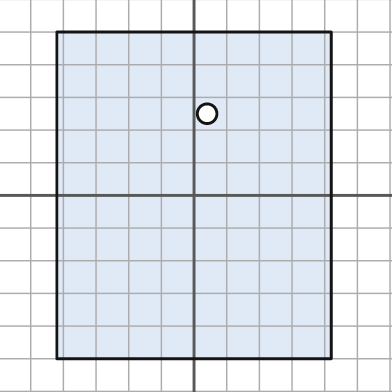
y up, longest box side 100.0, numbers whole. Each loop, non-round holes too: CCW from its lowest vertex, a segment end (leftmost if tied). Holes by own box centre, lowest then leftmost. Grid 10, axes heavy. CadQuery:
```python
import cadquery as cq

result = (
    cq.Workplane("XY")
    .moveTo(-42.0, -50.0)
    .lineTo(42.0, -50.0)
    .lineTo(42.0, 50.0)
    .lineTo(-42.0, 50.0)
    .close()
    .moveTo(4.0, 25.0)
    .circle(3.0)
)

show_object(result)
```